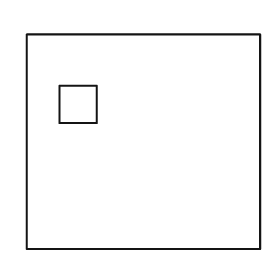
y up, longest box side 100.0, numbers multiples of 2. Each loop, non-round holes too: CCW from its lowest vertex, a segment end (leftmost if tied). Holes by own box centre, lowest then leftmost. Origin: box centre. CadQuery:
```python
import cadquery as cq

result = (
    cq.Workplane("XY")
    .moveTo(-50.0, -46.0)
    .lineTo(50.0, -46.0)
    .lineTo(50.0, 46.0)
    .lineTo(-50.0, 46.0)
    .close()
    .moveTo(-36.0, 8.0)
    .lineTo(-20.0, 8.0)
    .lineTo(-20.0, 24.0)
    .lineTo(-36.0, 24.0)
    .close()
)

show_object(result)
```